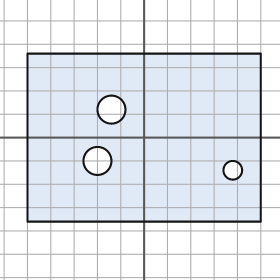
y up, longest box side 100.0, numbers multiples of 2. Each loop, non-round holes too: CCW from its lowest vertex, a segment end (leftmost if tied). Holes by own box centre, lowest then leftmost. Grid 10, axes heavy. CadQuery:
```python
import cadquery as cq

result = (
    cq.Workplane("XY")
    .moveTo(-50.0, -36.0)
    .lineTo(50.0, -36.0)
    .lineTo(50.0, 36.0)
    .lineTo(-50.0, 36.0)
    .close()
    .moveTo(38.0, -14.0)
    .circle(4.0)
    .moveTo(-20.0, -10.0)
    .circle(6.0)
    .moveTo(-14.0, 12.0)
    .circle(6.0)
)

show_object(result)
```